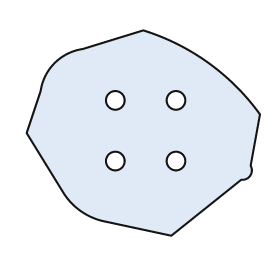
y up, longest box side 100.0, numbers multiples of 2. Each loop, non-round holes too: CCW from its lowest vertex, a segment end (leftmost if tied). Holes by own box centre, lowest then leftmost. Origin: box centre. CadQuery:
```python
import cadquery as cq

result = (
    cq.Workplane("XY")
    .moveTo(12.0, -44.0)
    .lineTo(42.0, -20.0)
    .threePointArc((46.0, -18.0), (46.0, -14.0))
    .lineTo(50.0, 8.0)
    .threePointArc((28.0, 30.0), (0.0, 44.0))
    .lineTo(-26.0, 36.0)
    .threePointArc((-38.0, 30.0), (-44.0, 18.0))
    .lineTo(-50.0, 0.0)
    .lineTo(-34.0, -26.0)
    .threePointArc((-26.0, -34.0), (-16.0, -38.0))
    .close()
    .moveTo(-12.0, -12.0)
    .circle(4.0)
    .moveTo(14.0, -12.0)
    .circle(4.0)
    .moveTo(-12.0, 14.0)
    .circle(4.0)
    .moveTo(14.0, 14.0)
    .circle(4.0)
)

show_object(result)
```